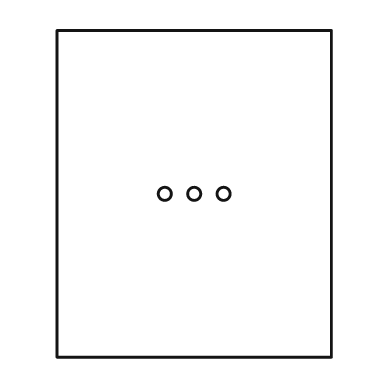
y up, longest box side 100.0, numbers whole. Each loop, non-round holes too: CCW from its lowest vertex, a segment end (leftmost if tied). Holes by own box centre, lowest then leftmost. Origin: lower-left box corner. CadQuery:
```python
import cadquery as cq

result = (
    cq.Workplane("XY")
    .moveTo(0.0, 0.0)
    .lineTo(84.0, 0.0)
    .lineTo(84.0, 100.0)
    .lineTo(0.0, 100.0)
    .close()
    .moveTo(33.0, 50.0)
    .circle(2.0)
    .moveTo(42.0, 50.0)
    .circle(2.0)
    .moveTo(51.0, 50.0)
    .circle(2.0)
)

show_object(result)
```